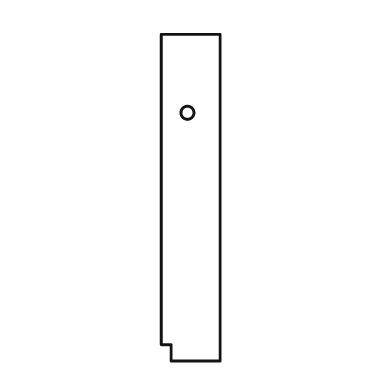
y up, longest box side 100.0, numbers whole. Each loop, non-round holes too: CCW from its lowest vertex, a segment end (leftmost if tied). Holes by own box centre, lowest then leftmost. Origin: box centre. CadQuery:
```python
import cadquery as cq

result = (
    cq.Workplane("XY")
    .moveTo(-6.0, -50.0)
    .lineTo(9.0, -50.0)
    .lineTo(9.0, 50.0)
    .lineTo(-9.0, 50.0)
    .lineTo(-9.0, -45.0)
    .lineTo(-6.0, -45.0)
    .close()
    .moveTo(-1.0, 26.0)
    .circle(2.0)
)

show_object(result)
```